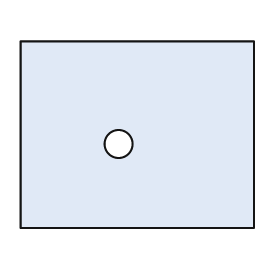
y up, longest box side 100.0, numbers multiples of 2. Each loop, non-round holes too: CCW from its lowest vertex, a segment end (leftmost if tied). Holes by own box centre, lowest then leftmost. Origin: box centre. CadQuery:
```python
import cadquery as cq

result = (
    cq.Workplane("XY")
    .moveTo(-50.0, -40.0)
    .lineTo(50.0, -40.0)
    .lineTo(50.0, 40.0)
    .lineTo(-50.0, 40.0)
    .close()
    .moveTo(-8.0, -4.0)
    .circle(6.0)
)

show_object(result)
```